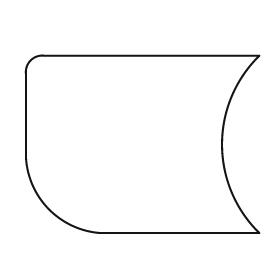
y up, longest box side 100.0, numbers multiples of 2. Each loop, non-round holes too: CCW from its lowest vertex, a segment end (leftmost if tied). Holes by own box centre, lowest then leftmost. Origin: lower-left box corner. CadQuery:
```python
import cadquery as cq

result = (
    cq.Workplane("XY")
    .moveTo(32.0, 0.0)
    .lineTo(100.0, 0.0)
    .threePointArc((84.0, 38.0), (100.0, 76.0))
    .lineTo(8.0, 76.0)
    .threePointArc((2.0, 74.0), (0.0, 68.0))
    .lineTo(0.0, 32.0)
    .threePointArc((10.0, 10.0), (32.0, 0.0))
    .close()
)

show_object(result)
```